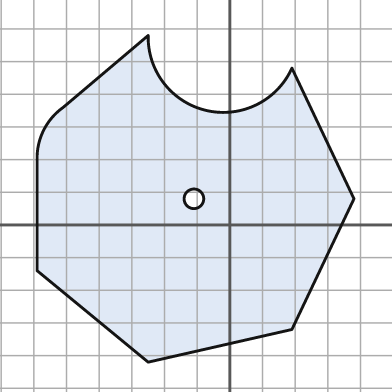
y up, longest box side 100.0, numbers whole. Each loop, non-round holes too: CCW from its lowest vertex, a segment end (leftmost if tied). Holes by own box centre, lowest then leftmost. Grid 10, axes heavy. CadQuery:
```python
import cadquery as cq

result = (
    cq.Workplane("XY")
    .moveTo(-25.0, -42.0)
    .lineTo(19.0, -32.0)
    .lineTo(38.0, 8.0)
    .lineTo(19.0, 48.0)
    .threePointArc((-7.0, 35.0), (-25.0, 58.0))
    .lineTo(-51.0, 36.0)
    .threePointArc((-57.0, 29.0), (-59.0, 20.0))
    .lineTo(-59.0, -14.0)
    .close()
    .moveTo(-11.0, 8.0)
    .circle(3.0)
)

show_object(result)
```